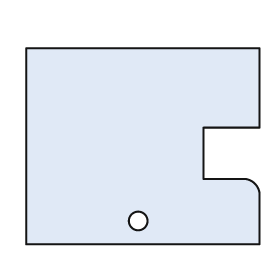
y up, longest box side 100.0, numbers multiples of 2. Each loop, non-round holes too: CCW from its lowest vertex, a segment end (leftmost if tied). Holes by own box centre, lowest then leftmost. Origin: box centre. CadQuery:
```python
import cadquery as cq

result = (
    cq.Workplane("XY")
    .moveTo(-50.0, -42.0)
    .lineTo(50.0, -42.0)
    .lineTo(50.0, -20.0)
    .threePointArc((48.0, -16.0), (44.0, -14.0))
    .lineTo(26.0, -14.0)
    .lineTo(26.0, 8.0)
    .lineTo(50.0, 8.0)
    .lineTo(50.0, 42.0)
    .lineTo(-50.0, 42.0)
    .close()
    .moveTo(-2.0, -32.0)
    .circle(4.0)
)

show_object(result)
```